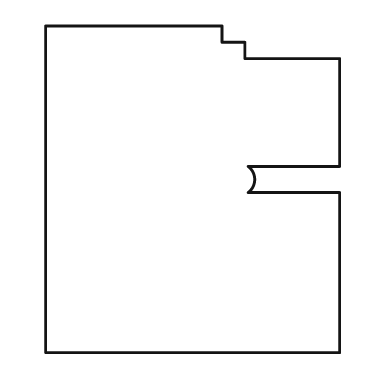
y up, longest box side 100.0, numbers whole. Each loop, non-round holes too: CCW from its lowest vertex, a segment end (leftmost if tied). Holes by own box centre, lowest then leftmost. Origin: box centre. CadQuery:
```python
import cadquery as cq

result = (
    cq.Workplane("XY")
    .moveTo(-45.0, -50.0)
    .lineTo(45.0, -50.0)
    .lineTo(45.0, -1.0)
    .lineTo(17.0, -1.0)
    .threePointArc((19.0, 3.0), (17.0, 7.0))
    .lineTo(45.0, 7.0)
    .lineTo(45.0, 40.0)
    .lineTo(16.0, 40.0)
    .lineTo(16.0, 45.0)
    .lineTo(9.0, 45.0)
    .lineTo(9.0, 50.0)
    .lineTo(-45.0, 50.0)
    .close()
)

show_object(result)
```